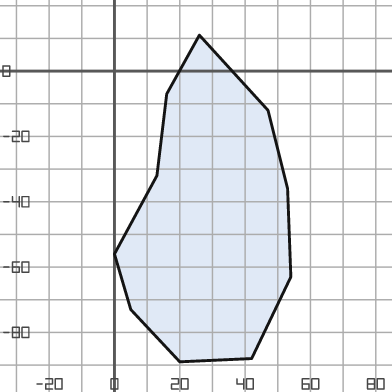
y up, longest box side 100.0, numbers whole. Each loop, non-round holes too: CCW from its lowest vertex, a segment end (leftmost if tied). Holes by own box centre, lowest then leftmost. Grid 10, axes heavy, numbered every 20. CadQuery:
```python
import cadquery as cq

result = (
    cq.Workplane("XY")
    .moveTo(20.0, -89.0)
    .lineTo(42.0, -88.0)
    .lineTo(54.0, -63.0)
    .lineTo(53.0, -36.0)
    .lineTo(47.0, -12.0)
    .lineTo(26.0, 11.0)
    .lineTo(16.0, -7.0)
    .lineTo(13.0, -32.0)
    .lineTo(0.0, -56.0)
    .lineTo(5.0, -73.0)
    .close()
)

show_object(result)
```